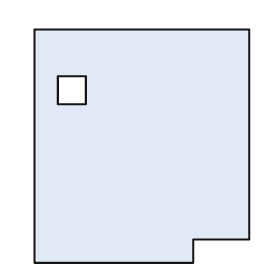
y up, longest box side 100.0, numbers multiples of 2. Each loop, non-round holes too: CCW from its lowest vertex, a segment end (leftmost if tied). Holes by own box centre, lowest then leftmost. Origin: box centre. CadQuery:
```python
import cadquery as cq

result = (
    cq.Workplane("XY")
    .moveTo(-46.0, -50.0)
    .lineTo(22.0, -50.0)
    .lineTo(22.0, -40.0)
    .lineTo(46.0, -40.0)
    .lineTo(46.0, 50.0)
    .lineTo(-46.0, 50.0)
    .close()
    .moveTo(-36.0, 18.0)
    .lineTo(-24.0, 18.0)
    .lineTo(-24.0, 30.0)
    .lineTo(-36.0, 30.0)
    .close()
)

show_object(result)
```